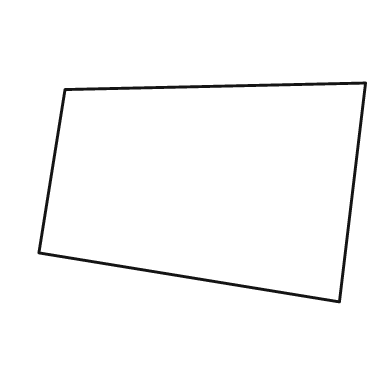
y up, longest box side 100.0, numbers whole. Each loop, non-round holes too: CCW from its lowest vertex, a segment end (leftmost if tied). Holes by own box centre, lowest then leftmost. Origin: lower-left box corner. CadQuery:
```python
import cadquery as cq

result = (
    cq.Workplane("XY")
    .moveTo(92.0, 0.0)
    .lineTo(100.0, 67.0)
    .lineTo(8.0, 65.0)
    .lineTo(0.0, 15.0)
    .close()
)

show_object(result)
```